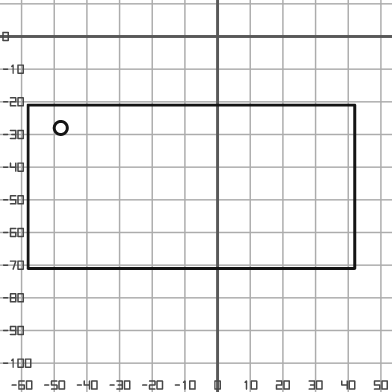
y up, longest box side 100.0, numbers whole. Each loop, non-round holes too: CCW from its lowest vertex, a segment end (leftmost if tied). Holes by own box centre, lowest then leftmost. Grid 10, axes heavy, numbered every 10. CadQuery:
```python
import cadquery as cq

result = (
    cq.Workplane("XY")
    .moveTo(-58.0, -71.0)
    .lineTo(42.0, -71.0)
    .lineTo(42.0, -21.0)
    .lineTo(-58.0, -21.0)
    .close()
    .moveTo(-48.0, -28.0)
    .circle(2.0)
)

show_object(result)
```